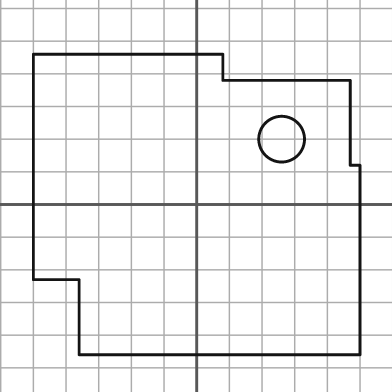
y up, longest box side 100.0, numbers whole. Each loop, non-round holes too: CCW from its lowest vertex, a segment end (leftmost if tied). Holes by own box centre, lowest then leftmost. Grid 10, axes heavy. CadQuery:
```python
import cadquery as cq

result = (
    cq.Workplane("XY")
    .moveTo(-36.0, -46.0)
    .lineTo(50.0, -46.0)
    .lineTo(50.0, 12.0)
    .lineTo(47.0, 12.0)
    .lineTo(47.0, 38.0)
    .lineTo(8.0, 38.0)
    .lineTo(8.0, 46.0)
    .lineTo(-50.0, 46.0)
    .lineTo(-50.0, -23.0)
    .lineTo(-36.0, -23.0)
    .close()
    .moveTo(26.0, 20.0)
    .circle(7.0)
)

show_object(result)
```